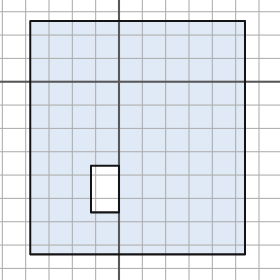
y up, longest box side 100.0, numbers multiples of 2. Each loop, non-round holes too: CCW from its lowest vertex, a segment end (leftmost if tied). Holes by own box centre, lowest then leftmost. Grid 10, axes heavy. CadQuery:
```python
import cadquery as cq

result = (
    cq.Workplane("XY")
    .moveTo(-38.0, -74.0)
    .lineTo(54.0, -74.0)
    .lineTo(54.0, 26.0)
    .lineTo(-38.0, 26.0)
    .close()
    .moveTo(-12.0, -56.0)
    .lineTo(0.0, -56.0)
    .lineTo(0.0, -36.0)
    .lineTo(-12.0, -36.0)
    .close()
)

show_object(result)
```